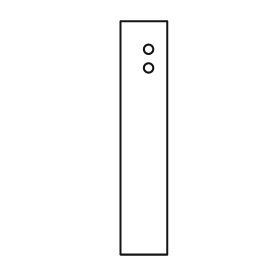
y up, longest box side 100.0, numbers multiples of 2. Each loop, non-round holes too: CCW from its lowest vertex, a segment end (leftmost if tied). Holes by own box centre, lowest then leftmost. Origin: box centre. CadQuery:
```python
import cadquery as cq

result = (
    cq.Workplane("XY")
    .moveTo(-10.0, -50.0)
    .lineTo(10.0, -50.0)
    .lineTo(10.0, 50.0)
    .lineTo(-10.0, 50.0)
    .close()
    .moveTo(2.0, 30.0)
    .circle(2.0)
    .moveTo(2.0, 38.0)
    .circle(2.0)
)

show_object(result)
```